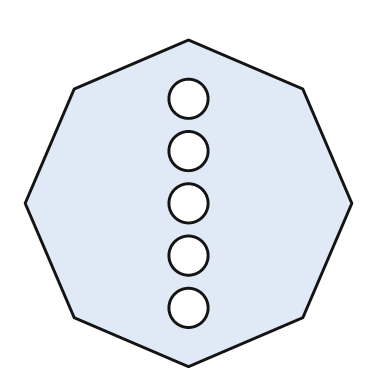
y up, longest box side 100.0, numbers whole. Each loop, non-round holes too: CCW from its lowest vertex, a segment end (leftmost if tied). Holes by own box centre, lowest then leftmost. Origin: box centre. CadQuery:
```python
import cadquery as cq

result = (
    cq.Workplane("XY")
    .moveTo(0.0, -50.0)
    .lineTo(35.0, -35.0)
    .lineTo(50.0, 0.0)
    .lineTo(35.0, 35.0)
    .lineTo(0.0, 50.0)
    .lineTo(-35.0, 35.0)
    .lineTo(-50.0, 0.0)
    .lineTo(-35.0, -35.0)
    .close()
    .moveTo(0.0, -32.0)
    .circle(6.0)
    .moveTo(0.0, -16.0)
    .circle(6.0)
    .moveTo(0.0, 0.0)
    .circle(6.0)
    .moveTo(0.0, 16.0)
    .circle(6.0)
    .moveTo(0.0, 32.0)
    .circle(6.0)
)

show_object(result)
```